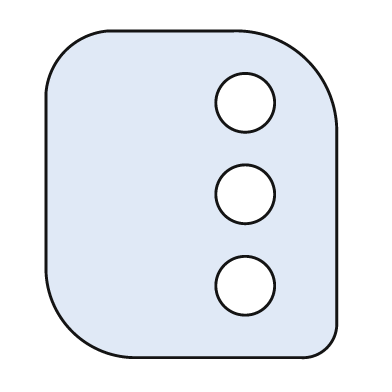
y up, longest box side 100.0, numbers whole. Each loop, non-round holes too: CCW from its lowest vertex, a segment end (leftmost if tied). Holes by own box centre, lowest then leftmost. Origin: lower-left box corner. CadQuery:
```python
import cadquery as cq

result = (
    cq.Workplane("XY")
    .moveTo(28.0, 0.0)
    .lineTo(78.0, 0.0)
    .threePointArc((86.0, 3.0), (89.0, 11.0))
    .lineTo(89.0, 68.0)
    .threePointArc((80.0, 91.0), (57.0, 100.0))
    .lineTo(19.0, 100.0)
    .threePointArc((6.0, 94.0), (0.0, 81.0))
    .lineTo(0.0, 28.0)
    .threePointArc((8.0, 8.0), (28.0, 0.0))
    .close()
    .moveTo(61.0, 22.0)
    .circle(9.0)
    .moveTo(61.0, 50.0)
    .circle(9.0)
    .moveTo(61.0, 78.0)
    .circle(9.0)
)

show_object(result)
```